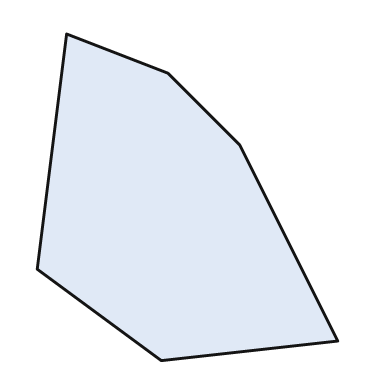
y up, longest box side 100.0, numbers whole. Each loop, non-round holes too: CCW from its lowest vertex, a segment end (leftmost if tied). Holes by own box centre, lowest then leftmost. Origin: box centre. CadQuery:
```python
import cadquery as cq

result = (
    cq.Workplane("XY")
    .moveTo(-8.0, -50.0)
    .lineTo(46.0, -44.0)
    .lineTo(16.0, 16.0)
    .lineTo(-6.0, 38.0)
    .lineTo(-37.0, 50.0)
    .lineTo(-46.0, -22.0)
    .close()
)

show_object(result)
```